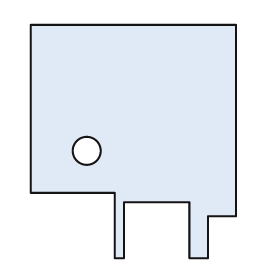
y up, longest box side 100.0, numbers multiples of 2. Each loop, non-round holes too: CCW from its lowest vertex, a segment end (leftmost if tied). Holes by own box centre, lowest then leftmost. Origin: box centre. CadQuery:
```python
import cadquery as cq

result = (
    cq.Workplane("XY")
    .moveTo(-8.0, -50.0)
    .lineTo(-4.0, -50.0)
    .lineTo(-4.0, -26.0)
    .lineTo(24.0, -26.0)
    .lineTo(24.0, -50.0)
    .lineTo(32.0, -50.0)
    .lineTo(32.0, -32.0)
    .lineTo(44.0, -32.0)
    .lineTo(44.0, 50.0)
    .lineTo(-44.0, 50.0)
    .lineTo(-44.0, -22.0)
    .lineTo(-8.0, -22.0)
    .close()
    .moveTo(-20.0, -4.0)
    .circle(6.0)
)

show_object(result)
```